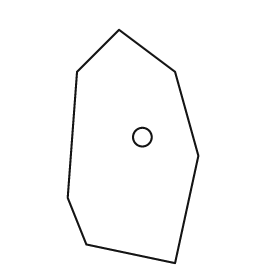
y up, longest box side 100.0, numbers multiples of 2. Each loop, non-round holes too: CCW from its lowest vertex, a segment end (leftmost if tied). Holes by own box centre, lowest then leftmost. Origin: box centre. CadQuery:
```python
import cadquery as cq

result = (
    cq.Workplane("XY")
    .moveTo(18.0, -50.0)
    .lineTo(28.0, -4.0)
    .lineTo(18.0, 32.0)
    .lineTo(-6.0, 50.0)
    .lineTo(-24.0, 32.0)
    .lineTo(-28.0, -22.0)
    .lineTo(-20.0, -42.0)
    .close()
    .moveTo(4.0, 4.0)
    .circle(4.0)
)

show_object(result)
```